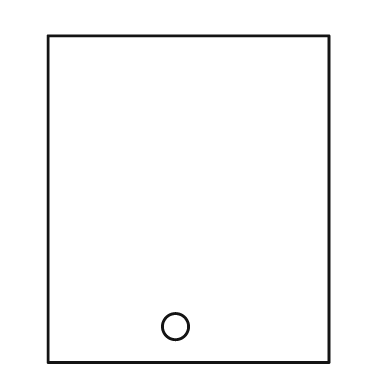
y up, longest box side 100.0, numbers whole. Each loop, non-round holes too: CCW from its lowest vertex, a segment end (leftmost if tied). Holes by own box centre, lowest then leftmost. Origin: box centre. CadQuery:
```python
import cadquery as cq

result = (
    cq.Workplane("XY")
    .moveTo(-43.0, -50.0)
    .lineTo(43.0, -50.0)
    .lineTo(43.0, 50.0)
    .lineTo(-43.0, 50.0)
    .close()
    .moveTo(-4.0, -39.0)
    .circle(4.0)
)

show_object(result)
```